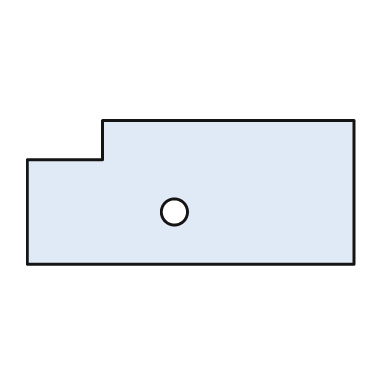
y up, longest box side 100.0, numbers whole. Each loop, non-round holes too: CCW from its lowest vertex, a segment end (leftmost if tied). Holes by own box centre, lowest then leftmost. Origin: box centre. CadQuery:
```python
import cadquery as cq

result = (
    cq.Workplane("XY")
    .moveTo(-50.0, -22.0)
    .lineTo(50.0, -22.0)
    .lineTo(50.0, 22.0)
    .lineTo(-27.0, 22.0)
    .lineTo(-27.0, 10.0)
    .lineTo(-50.0, 10.0)
    .close()
    .moveTo(-5.0, -6.0)
    .circle(4.0)
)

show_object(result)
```